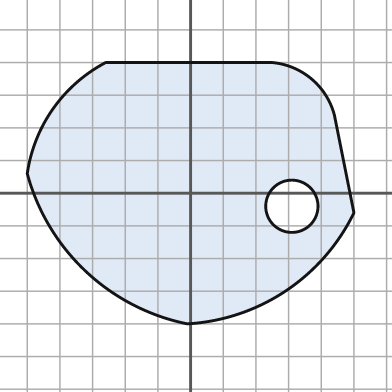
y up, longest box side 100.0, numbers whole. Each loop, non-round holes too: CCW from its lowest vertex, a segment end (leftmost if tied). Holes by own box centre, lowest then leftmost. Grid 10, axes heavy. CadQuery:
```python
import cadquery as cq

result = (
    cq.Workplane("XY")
    .moveTo(-1.0, -40.0)
    .threePointArc((29.0, -30.0), (50.0, -6.0))
    .lineTo(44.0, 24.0)
    .threePointArc((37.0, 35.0), (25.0, 40.0))
    .lineTo(-26.0, 40.0)
    .threePointArc((-42.0, 26.0), (-50.0, 6.0))
    .threePointArc((-32.0, -24.0), (-1.0, -40.0))
    .close()
    .moveTo(31.0, -4.0)
    .circle(8.0)
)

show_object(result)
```